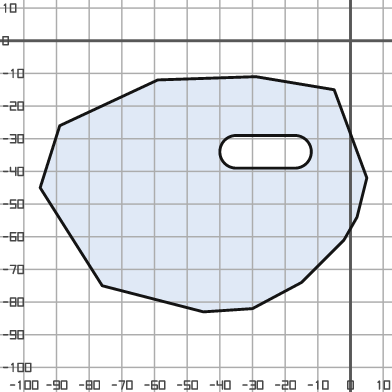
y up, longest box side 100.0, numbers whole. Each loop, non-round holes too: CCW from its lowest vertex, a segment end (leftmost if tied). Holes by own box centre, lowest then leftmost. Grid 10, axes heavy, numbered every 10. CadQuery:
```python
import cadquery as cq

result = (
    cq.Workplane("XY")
    .moveTo(-45.0, -83.0)
    .lineTo(-30.0, -82.0)
    .lineTo(-15.0, -74.0)
    .lineTo(-2.0, -61.0)
    .lineTo(2.0, -54.0)
    .lineTo(5.0, -42.0)
    .lineTo(-5.0, -15.0)
    .lineTo(-29.0, -11.0)
    .lineTo(-59.0, -12.0)
    .lineTo(-89.0, -26.0)
    .lineTo(-95.0, -45.0)
    .lineTo(-76.0, -75.0)
    .close()
    .moveTo(-35.0, -39.0)
    .lineTo(-17.0, -39.0)
    .threePointArc((-12.0, -34.0), (-17.0, -29.0))
    .lineTo(-35.0, -29.0)
    .threePointArc((-40.0, -34.0), (-35.0, -39.0))
    .close()
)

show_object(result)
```